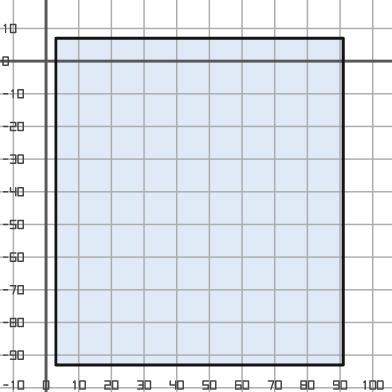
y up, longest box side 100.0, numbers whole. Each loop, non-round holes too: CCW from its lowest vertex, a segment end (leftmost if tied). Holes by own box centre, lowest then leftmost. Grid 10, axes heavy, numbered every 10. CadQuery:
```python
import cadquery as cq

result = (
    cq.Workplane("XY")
    .moveTo(3.0, -93.0)
    .lineTo(91.0, -93.0)
    .lineTo(91.0, 7.0)
    .lineTo(3.0, 7.0)
    .close()
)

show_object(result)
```